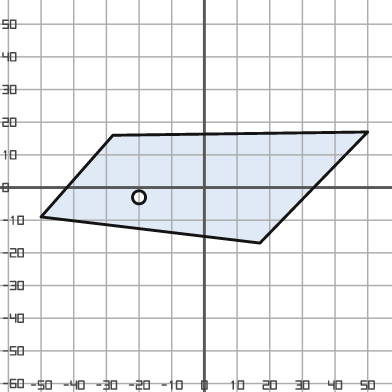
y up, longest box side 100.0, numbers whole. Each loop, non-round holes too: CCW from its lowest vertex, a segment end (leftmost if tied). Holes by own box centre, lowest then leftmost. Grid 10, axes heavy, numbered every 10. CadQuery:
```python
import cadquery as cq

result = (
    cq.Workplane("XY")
    .moveTo(17.0, -17.0)
    .lineTo(50.0, 17.0)
    .lineTo(-28.0, 16.0)
    .lineTo(-50.0, -9.0)
    .close()
    .moveTo(-20.0, -3.0)
    .circle(2.0)
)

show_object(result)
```